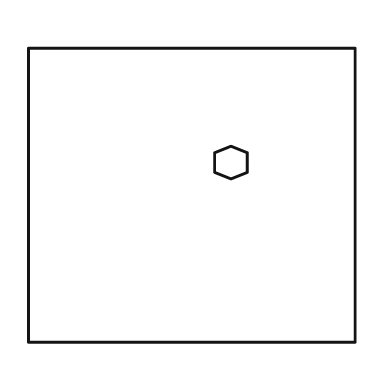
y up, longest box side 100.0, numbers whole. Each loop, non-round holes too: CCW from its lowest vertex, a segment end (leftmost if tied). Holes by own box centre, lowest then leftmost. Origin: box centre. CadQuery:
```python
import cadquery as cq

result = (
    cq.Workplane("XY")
    .moveTo(-50.0, -45.0)
    .lineTo(50.0, -45.0)
    .lineTo(50.0, 45.0)
    .lineTo(-50.0, 45.0)
    .close()
    .moveTo(12.0, 5.0)
    .lineTo(17.0, 7.0)
    .lineTo(17.0, 13.0)
    .lineTo(12.0, 15.0)
    .lineTo(7.0, 13.0)
    .lineTo(7.0, 7.0)
    .close()
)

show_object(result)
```